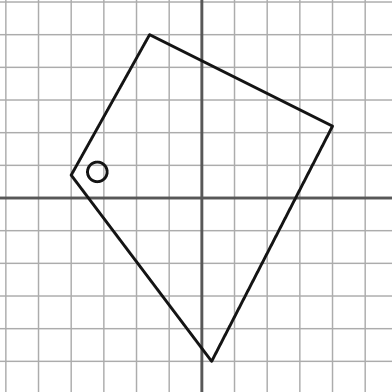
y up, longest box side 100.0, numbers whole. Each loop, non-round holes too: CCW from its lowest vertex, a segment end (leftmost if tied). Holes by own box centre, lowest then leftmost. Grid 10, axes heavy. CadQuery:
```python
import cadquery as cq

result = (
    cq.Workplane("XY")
    .moveTo(3.0, -50.0)
    .lineTo(40.0, 22.0)
    .lineTo(-16.0, 50.0)
    .lineTo(-40.0, 7.0)
    .close()
    .moveTo(-32.0, 8.0)
    .circle(3.0)
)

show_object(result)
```